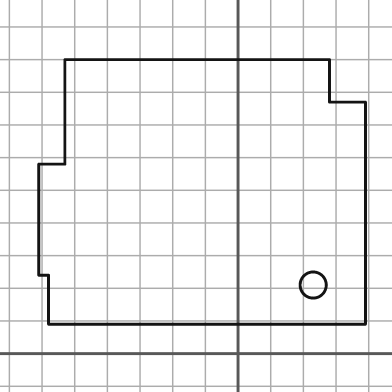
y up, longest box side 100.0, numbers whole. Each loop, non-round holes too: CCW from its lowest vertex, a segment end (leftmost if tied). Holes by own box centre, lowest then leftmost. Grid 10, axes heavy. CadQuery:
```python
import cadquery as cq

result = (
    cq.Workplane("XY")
    .moveTo(-58.0, 9.0)
    .lineTo(39.0, 9.0)
    .lineTo(39.0, 77.0)
    .lineTo(28.0, 77.0)
    .lineTo(28.0, 90.0)
    .lineTo(-53.0, 90.0)
    .lineTo(-53.0, 58.0)
    .lineTo(-61.0, 58.0)
    .lineTo(-61.0, 24.0)
    .lineTo(-58.0, 24.0)
    .close()
    .moveTo(23.0, 21.0)
    .circle(4.0)
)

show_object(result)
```